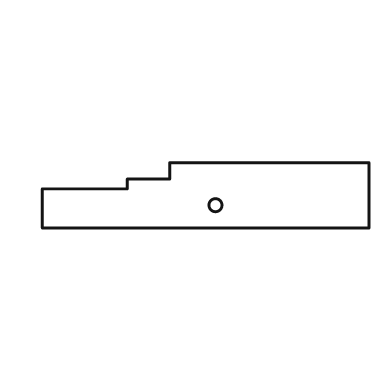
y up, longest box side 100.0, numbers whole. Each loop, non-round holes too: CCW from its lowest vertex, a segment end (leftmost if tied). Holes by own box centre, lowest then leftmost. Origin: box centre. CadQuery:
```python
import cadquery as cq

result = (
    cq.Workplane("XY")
    .moveTo(-50.0, -10.0)
    .lineTo(50.0, -10.0)
    .lineTo(50.0, 10.0)
    .lineTo(-11.0, 10.0)
    .lineTo(-11.0, 5.0)
    .lineTo(-24.0, 5.0)
    .lineTo(-24.0, 2.0)
    .lineTo(-50.0, 2.0)
    .close()
    .moveTo(3.0, -3.0)
    .circle(2.0)
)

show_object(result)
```